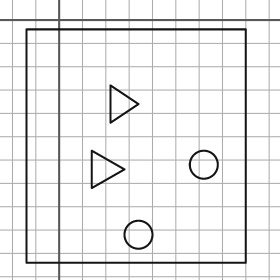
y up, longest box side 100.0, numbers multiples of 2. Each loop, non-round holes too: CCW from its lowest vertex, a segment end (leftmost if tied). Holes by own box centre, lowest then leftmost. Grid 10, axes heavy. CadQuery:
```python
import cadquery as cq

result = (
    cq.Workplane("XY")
    .moveTo(-14.0, -104.0)
    .lineTo(80.0, -104.0)
    .lineTo(80.0, -4.0)
    .lineTo(-14.0, -4.0)
    .close()
    .moveTo(34.0, -92.0)
    .circle(6.0)
    .moveTo(14.0, -72.0)
    .lineTo(28.0, -64.0)
    .lineTo(14.0, -56.0)
    .close()
    .moveTo(62.0, -62.0)
    .circle(6.0)
    .moveTo(22.0, -44.0)
    .lineTo(34.0, -36.0)
    .lineTo(22.0, -28.0)
    .close()
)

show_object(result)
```